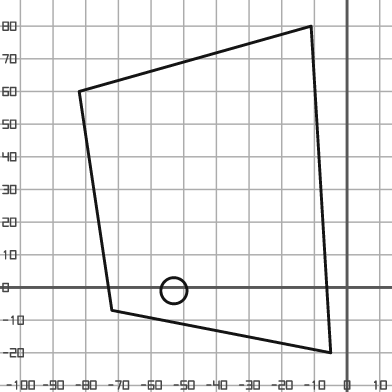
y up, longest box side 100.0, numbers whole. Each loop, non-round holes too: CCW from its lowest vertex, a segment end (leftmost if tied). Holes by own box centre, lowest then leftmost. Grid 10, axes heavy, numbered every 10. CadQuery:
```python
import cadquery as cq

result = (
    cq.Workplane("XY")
    .moveTo(-5.0, -20.0)
    .lineTo(-11.0, 80.0)
    .lineTo(-82.0, 60.0)
    .lineTo(-72.0, -7.0)
    .close()
    .moveTo(-53.0, -1.0)
    .circle(4.0)
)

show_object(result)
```